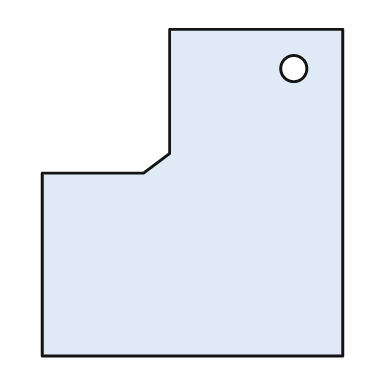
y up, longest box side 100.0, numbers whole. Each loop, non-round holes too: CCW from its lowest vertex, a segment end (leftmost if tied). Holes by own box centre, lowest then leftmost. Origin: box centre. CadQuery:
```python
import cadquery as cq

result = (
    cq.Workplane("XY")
    .moveTo(-46.0, -50.0)
    .lineTo(46.0, -50.0)
    .lineTo(46.0, 50.0)
    .lineTo(-7.0, 50.0)
    .lineTo(-7.0, 12.0)
    .lineTo(-15.0, 6.0)
    .lineTo(-46.0, 6.0)
    .close()
    .moveTo(31.0, 38.0)
    .circle(4.0)
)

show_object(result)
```